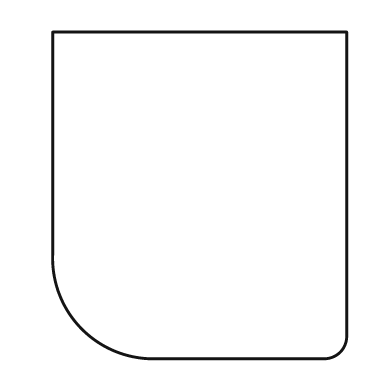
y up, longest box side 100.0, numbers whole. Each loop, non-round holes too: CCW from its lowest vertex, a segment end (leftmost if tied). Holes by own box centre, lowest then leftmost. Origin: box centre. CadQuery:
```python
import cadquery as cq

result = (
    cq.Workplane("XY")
    .moveTo(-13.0, -50.0)
    .lineTo(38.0, -50.0)
    .threePointArc((43.0, -48.0), (45.0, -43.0))
    .lineTo(45.0, 50.0)
    .lineTo(-45.0, 50.0)
    .lineTo(-45.0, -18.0)
    .threePointArc((-36.0, -41.0), (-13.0, -50.0))
    .close()
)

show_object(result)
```